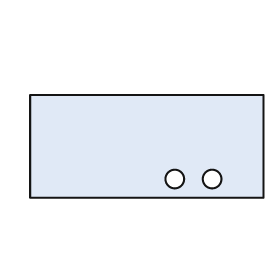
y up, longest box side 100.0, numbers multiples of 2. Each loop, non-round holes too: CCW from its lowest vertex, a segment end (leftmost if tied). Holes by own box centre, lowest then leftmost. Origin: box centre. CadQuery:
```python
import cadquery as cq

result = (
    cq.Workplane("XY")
    .moveTo(-50.0, -22.0)
    .lineTo(50.0, -22.0)
    .lineTo(50.0, 22.0)
    .lineTo(-50.0, 22.0)
    .close()
    .moveTo(12.0, -14.0)
    .circle(4.0)
    .moveTo(28.0, -14.0)
    .circle(4.0)
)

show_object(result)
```